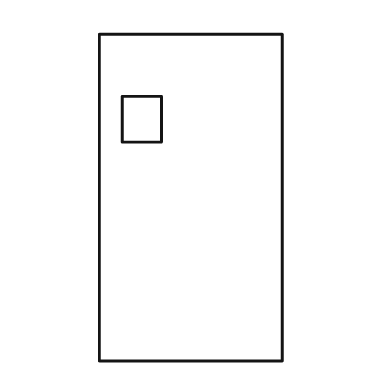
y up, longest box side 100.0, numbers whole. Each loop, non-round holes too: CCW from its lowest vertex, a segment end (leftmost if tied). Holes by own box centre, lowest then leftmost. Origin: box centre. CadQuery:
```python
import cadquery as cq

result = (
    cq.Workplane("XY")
    .moveTo(-28.0, -50.0)
    .lineTo(28.0, -50.0)
    .lineTo(28.0, 50.0)
    .lineTo(-28.0, 50.0)
    .close()
    .moveTo(-21.0, 17.0)
    .lineTo(-9.0, 17.0)
    .lineTo(-9.0, 31.0)
    .lineTo(-21.0, 31.0)
    .close()
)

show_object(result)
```